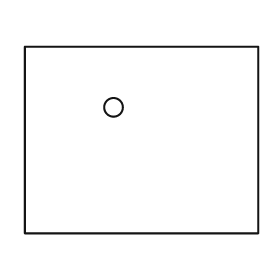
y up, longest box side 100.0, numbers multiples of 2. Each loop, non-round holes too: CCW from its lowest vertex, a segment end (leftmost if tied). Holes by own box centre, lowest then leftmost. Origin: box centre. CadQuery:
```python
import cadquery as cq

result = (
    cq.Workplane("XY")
    .moveTo(-50.0, -40.0)
    .lineTo(50.0, -40.0)
    .lineTo(50.0, 40.0)
    .lineTo(-50.0, 40.0)
    .close()
    .moveTo(-12.0, 14.0)
    .circle(4.0)
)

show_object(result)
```